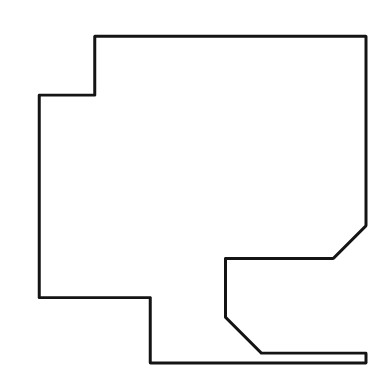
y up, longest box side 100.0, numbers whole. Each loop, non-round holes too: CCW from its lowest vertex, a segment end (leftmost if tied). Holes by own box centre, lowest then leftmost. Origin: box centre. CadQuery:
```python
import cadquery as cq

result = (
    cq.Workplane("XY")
    .moveTo(-16.0, -50.0)
    .lineTo(50.0, -50.0)
    .lineTo(50.0, -47.0)
    .lineTo(18.0, -47.0)
    .lineTo(7.0, -36.0)
    .lineTo(7.0, -18.0)
    .lineTo(40.0, -18.0)
    .lineTo(50.0, -8.0)
    .lineTo(50.0, 50.0)
    .lineTo(-33.0, 50.0)
    .lineTo(-33.0, 32.0)
    .lineTo(-50.0, 32.0)
    .lineTo(-50.0, -30.0)
    .lineTo(-16.0, -30.0)
    .close()
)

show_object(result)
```